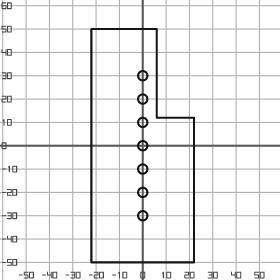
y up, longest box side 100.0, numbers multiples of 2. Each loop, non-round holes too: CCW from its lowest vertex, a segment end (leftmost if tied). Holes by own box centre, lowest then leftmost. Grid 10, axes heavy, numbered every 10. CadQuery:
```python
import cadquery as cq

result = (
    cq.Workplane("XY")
    .moveTo(-22.0, -50.0)
    .lineTo(22.0, -50.0)
    .lineTo(22.0, 12.0)
    .lineTo(6.0, 12.0)
    .lineTo(6.0, 50.0)
    .lineTo(-22.0, 50.0)
    .close()
    .moveTo(0.0, -30.0)
    .circle(2.0)
    .moveTo(0.0, -20.0)
    .circle(2.0)
    .moveTo(0.0, -10.0)
    .circle(2.0)
    .moveTo(0.0, 0.0)
    .circle(2.0)
    .moveTo(0.0, 10.0)
    .circle(2.0)
    .moveTo(0.0, 20.0)
    .circle(2.0)
    .moveTo(0.0, 30.0)
    .circle(2.0)
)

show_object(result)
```